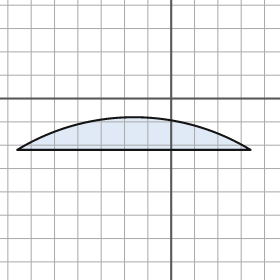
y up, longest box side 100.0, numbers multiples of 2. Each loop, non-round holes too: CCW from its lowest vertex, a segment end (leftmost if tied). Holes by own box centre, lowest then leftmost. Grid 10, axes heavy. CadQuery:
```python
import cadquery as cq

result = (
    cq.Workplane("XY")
    .moveTo(-66.0, -22.0)
    .lineTo(34.0, -22.0)
    .threePointArc((-16.0, -8.0), (-66.0, -22.0))
    .close()
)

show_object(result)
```